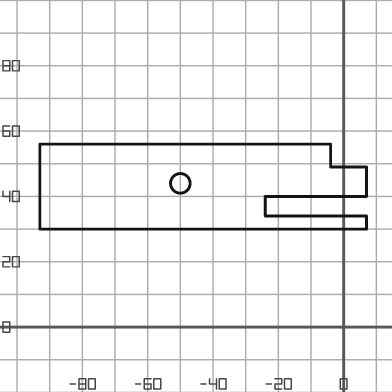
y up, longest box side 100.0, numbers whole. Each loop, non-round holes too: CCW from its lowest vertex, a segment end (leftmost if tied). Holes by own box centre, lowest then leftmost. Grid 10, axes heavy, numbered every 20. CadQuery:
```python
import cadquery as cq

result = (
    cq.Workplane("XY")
    .moveTo(-93.0, 30.0)
    .lineTo(7.0, 30.0)
    .lineTo(7.0, 34.0)
    .lineTo(-24.0, 34.0)
    .lineTo(-24.0, 40.0)
    .lineTo(7.0, 40.0)
    .lineTo(7.0, 49.0)
    .lineTo(-4.0, 49.0)
    .lineTo(-4.0, 56.0)
    .lineTo(-93.0, 56.0)
    .close()
    .moveTo(-50.0, 44.0)
    .circle(3.0)
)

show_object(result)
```